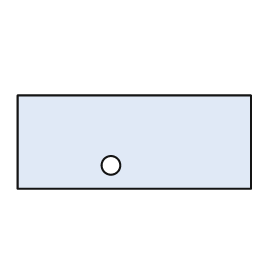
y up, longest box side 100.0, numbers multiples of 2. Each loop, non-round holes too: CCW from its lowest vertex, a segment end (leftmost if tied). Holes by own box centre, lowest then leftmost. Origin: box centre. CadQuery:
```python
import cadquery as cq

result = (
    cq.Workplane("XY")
    .moveTo(-50.0, -20.0)
    .lineTo(50.0, -20.0)
    .lineTo(50.0, 20.0)
    .lineTo(-50.0, 20.0)
    .close()
    .moveTo(-10.0, -10.0)
    .circle(4.0)
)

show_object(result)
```